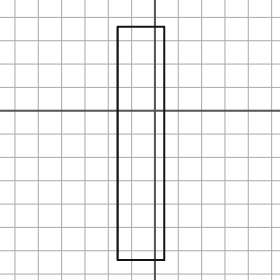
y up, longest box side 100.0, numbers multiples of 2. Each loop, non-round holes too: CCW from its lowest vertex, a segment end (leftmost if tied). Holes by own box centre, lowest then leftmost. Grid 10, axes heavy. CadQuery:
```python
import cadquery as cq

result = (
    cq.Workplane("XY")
    .moveTo(-16.0, -64.0)
    .lineTo(4.0, -64.0)
    .lineTo(4.0, 36.0)
    .lineTo(-16.0, 36.0)
    .close()
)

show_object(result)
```